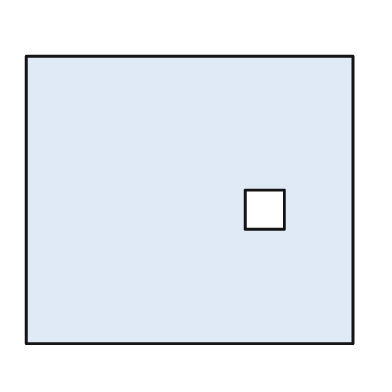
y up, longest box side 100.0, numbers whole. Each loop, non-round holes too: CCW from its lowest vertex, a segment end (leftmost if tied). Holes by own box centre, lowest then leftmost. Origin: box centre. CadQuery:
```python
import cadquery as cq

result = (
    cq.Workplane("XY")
    .moveTo(-50.0, -44.0)
    .lineTo(50.0, -44.0)
    .lineTo(50.0, 44.0)
    .lineTo(-50.0, 44.0)
    .close()
    .moveTo(17.0, -9.0)
    .lineTo(29.0, -9.0)
    .lineTo(29.0, 3.0)
    .lineTo(17.0, 3.0)
    .close()
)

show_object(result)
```